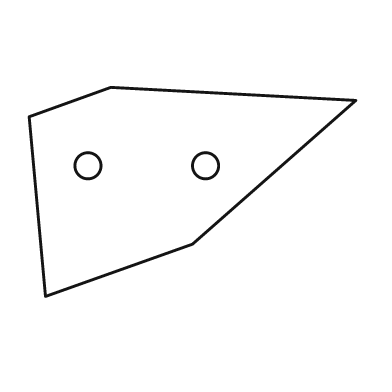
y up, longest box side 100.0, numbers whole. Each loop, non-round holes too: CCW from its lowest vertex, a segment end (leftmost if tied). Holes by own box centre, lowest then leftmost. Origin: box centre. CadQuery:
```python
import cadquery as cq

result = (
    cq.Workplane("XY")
    .moveTo(-45.0, -32.0)
    .lineTo(0.0, -16.0)
    .lineTo(50.0, 28.0)
    .lineTo(-25.0, 32.0)
    .lineTo(-50.0, 23.0)
    .close()
    .moveTo(-32.0, 8.0)
    .circle(4.0)
    .moveTo(4.0, 8.0)
    .circle(4.0)
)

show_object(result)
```